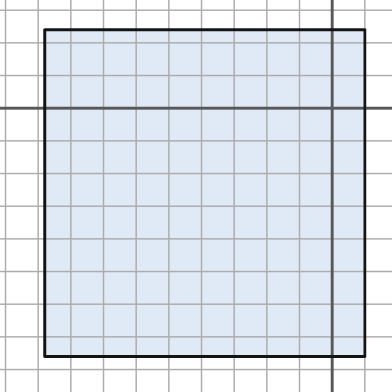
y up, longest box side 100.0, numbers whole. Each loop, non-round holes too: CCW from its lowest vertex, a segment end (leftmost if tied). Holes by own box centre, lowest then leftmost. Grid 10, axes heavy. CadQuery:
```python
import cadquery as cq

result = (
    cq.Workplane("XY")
    .moveTo(-88.0, -76.0)
    .lineTo(10.0, -76.0)
    .lineTo(10.0, 24.0)
    .lineTo(-88.0, 24.0)
    .close()
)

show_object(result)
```